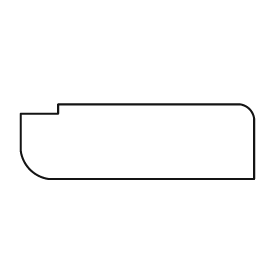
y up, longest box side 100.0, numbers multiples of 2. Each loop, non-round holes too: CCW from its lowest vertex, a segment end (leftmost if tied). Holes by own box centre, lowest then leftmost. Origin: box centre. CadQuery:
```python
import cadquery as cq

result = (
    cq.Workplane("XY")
    .moveTo(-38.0, -16.0)
    .lineTo(50.0, -16.0)
    .lineTo(50.0, 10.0)
    .threePointArc((48.0, 14.0), (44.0, 16.0))
    .lineTo(-34.0, 16.0)
    .lineTo(-34.0, 12.0)
    .lineTo(-50.0, 12.0)
    .lineTo(-50.0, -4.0)
    .threePointArc((-46.0, -12.0), (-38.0, -16.0))
    .close()
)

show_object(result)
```